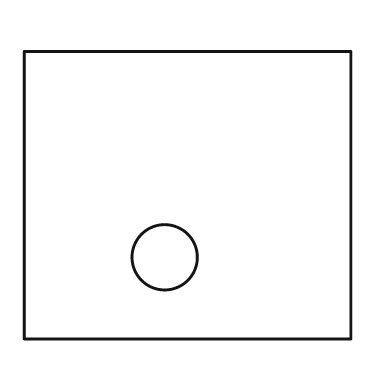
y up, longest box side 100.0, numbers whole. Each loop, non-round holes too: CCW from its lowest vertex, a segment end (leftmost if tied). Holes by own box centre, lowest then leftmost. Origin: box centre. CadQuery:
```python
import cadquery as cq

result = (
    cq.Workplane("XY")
    .moveTo(-50.0, -44.0)
    .lineTo(50.0, -44.0)
    .lineTo(50.0, 44.0)
    .lineTo(-50.0, 44.0)
    .close()
    .moveTo(-7.0, -19.0)
    .circle(10.0)
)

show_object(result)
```